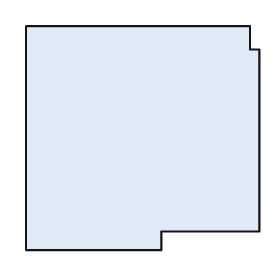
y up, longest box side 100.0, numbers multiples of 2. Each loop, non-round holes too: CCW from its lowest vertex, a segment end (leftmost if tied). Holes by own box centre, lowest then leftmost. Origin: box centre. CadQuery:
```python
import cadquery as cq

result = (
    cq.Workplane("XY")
    .moveTo(-50.0, -48.0)
    .lineTo(8.0, -48.0)
    .lineTo(8.0, -40.0)
    .lineTo(50.0, -40.0)
    .lineTo(50.0, 38.0)
    .lineTo(46.0, 38.0)
    .lineTo(46.0, 48.0)
    .lineTo(-50.0, 48.0)
    .close()
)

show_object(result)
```